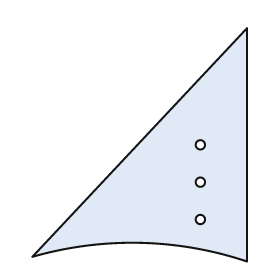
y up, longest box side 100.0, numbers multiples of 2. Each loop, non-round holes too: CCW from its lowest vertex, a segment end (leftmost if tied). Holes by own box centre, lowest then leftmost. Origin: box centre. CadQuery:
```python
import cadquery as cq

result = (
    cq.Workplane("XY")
    .moveTo(46.0, -50.0)
    .lineTo(46.0, 50.0)
    .lineTo(-46.0, -48.0)
    .threePointArc((0.0, -42.0), (46.0, -50.0))
    .close()
    .moveTo(26.0, -32.0)
    .circle(2.0)
    .moveTo(26.0, -16.0)
    .circle(2.0)
    .moveTo(26.0, 0.0)
    .circle(2.0)
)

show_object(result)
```